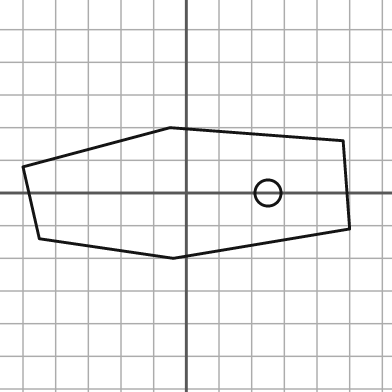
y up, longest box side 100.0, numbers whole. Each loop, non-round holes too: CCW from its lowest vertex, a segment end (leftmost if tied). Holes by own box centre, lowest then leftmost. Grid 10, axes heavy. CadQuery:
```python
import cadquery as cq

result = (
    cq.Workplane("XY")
    .moveTo(-4.0, -20.0)
    .lineTo(50.0, -11.0)
    .lineTo(48.0, 16.0)
    .lineTo(-5.0, 20.0)
    .lineTo(-50.0, 8.0)
    .lineTo(-45.0, -14.0)
    .close()
    .moveTo(25.0, 0.0)
    .circle(4.0)
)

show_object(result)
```